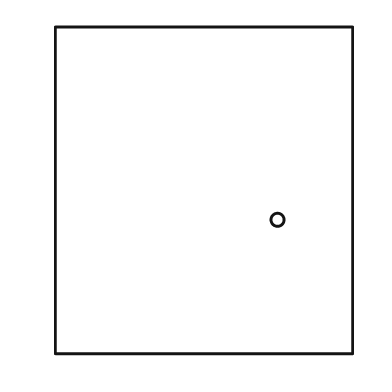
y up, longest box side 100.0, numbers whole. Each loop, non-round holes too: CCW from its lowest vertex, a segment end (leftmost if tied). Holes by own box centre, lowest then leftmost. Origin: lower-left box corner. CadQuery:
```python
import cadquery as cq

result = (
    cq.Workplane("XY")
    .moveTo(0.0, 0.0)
    .lineTo(91.0, 0.0)
    .lineTo(91.0, 100.0)
    .lineTo(0.0, 100.0)
    .close()
    .moveTo(68.0, 41.0)
    .circle(2.0)
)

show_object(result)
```